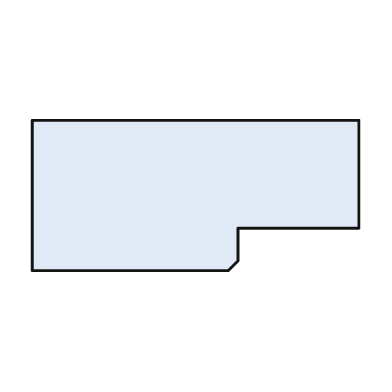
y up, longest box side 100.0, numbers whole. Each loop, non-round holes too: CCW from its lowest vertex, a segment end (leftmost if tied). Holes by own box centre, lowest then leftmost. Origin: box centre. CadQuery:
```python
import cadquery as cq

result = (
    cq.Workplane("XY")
    .moveTo(-50.0, -23.0)
    .lineTo(10.0, -23.0)
    .lineTo(13.0, -20.0)
    .lineTo(13.0, -10.0)
    .lineTo(50.0, -10.0)
    .lineTo(50.0, 23.0)
    .lineTo(-50.0, 23.0)
    .close()
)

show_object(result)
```